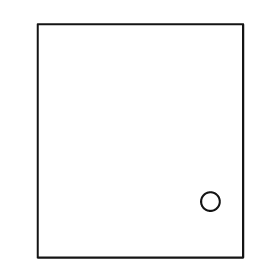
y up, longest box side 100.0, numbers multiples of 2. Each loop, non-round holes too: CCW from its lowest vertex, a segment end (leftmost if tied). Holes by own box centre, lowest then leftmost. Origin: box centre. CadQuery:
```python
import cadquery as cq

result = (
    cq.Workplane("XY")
    .moveTo(-44.0, -50.0)
    .lineTo(44.0, -50.0)
    .lineTo(44.0, 50.0)
    .lineTo(-44.0, 50.0)
    .close()
    .moveTo(30.0, -26.0)
    .circle(4.0)
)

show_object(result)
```